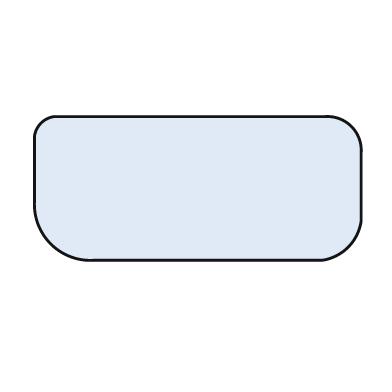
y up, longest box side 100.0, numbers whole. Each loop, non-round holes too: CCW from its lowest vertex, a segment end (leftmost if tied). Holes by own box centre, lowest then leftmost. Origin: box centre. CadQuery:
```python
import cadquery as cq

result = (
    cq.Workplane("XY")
    .moveTo(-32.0, -22.0)
    .lineTo(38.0, -22.0)
    .threePointArc((46.0, -18.0), (50.0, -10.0))
    .lineTo(50.0, 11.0)
    .threePointArc((47.0, 19.0), (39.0, 22.0))
    .lineTo(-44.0, 22.0)
    .threePointArc((-48.0, 20.0), (-50.0, 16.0))
    .lineTo(-50.0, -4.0)
    .threePointArc((-45.0, -17.0), (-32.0, -22.0))
    .close()
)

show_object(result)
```